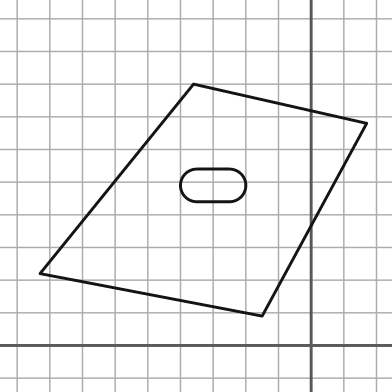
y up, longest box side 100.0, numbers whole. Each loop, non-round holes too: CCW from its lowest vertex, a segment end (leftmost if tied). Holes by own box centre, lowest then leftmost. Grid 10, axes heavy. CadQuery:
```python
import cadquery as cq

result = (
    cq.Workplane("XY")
    .moveTo(-15.0, 9.0)
    .lineTo(17.0, 68.0)
    .lineTo(-36.0, 80.0)
    .lineTo(-83.0, 22.0)
    .close()
    .moveTo(-35.0, 44.0)
    .lineTo(-25.0, 44.0)
    .threePointArc((-20.0, 49.0), (-25.0, 54.0))
    .lineTo(-35.0, 54.0)
    .threePointArc((-40.0, 49.0), (-35.0, 44.0))
    .close()
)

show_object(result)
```